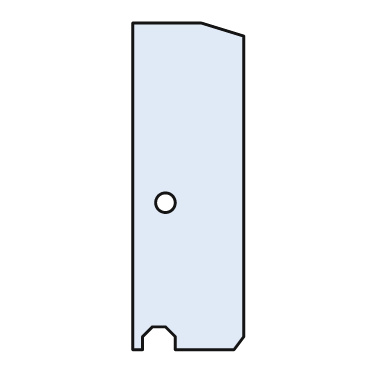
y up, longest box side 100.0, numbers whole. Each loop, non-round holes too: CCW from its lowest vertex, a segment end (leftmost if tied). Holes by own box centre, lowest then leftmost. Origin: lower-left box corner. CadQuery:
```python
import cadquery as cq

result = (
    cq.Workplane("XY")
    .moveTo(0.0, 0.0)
    .lineTo(3.0, 0.0)
    .lineTo(3.0, 4.0)
    .lineTo(6.0, 7.0)
    .lineTo(10.0, 7.0)
    .lineTo(13.0, 4.0)
    .lineTo(13.0, 0.0)
    .lineTo(31.0, 0.0)
    .lineTo(34.0, 4.0)
    .lineTo(34.0, 96.0)
    .lineTo(21.0, 100.0)
    .lineTo(0.0, 100.0)
    .close()
    .moveTo(10.0, 45.0)
    .circle(3.0)
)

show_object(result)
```